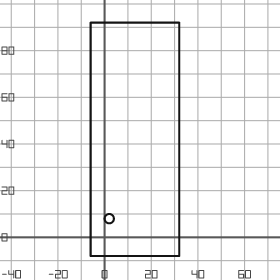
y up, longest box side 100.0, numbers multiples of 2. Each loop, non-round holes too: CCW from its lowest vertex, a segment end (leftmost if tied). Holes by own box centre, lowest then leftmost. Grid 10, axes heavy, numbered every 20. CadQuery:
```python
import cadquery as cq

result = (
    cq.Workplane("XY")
    .moveTo(-6.0, -8.0)
    .lineTo(32.0, -8.0)
    .lineTo(32.0, 92.0)
    .lineTo(-6.0, 92.0)
    .close()
    .moveTo(2.0, 8.0)
    .circle(2.0)
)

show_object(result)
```